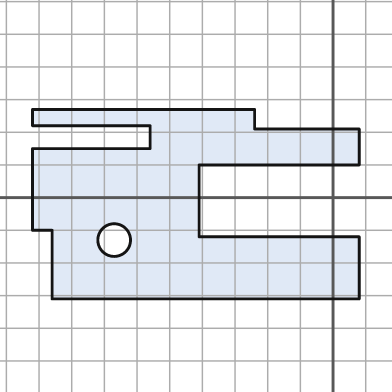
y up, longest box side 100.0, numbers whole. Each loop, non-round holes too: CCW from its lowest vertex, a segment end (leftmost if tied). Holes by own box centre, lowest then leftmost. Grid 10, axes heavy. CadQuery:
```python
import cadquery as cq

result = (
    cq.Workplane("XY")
    .moveTo(-86.0, -31.0)
    .lineTo(8.0, -31.0)
    .lineTo(8.0, -12.0)
    .lineTo(-41.0, -12.0)
    .lineTo(-41.0, 10.0)
    .lineTo(8.0, 10.0)
    .lineTo(8.0, 21.0)
    .lineTo(-24.0, 21.0)
    .lineTo(-24.0, 27.0)
    .lineTo(-92.0, 27.0)
    .lineTo(-92.0, 22.0)
    .lineTo(-56.0, 22.0)
    .lineTo(-56.0, 15.0)
    .lineTo(-92.0, 15.0)
    .lineTo(-92.0, -10.0)
    .lineTo(-86.0, -10.0)
    .close()
    .moveTo(-67.0, -13.0)
    .circle(5.0)
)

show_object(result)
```